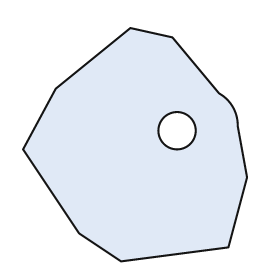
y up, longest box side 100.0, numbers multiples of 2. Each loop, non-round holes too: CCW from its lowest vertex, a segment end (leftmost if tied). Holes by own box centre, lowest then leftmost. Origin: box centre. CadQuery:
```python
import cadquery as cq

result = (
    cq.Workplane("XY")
    .moveTo(-6.0, -50.0)
    .lineTo(40.0, -44.0)
    .lineTo(48.0, -14.0)
    .lineTo(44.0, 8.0)
    .threePointArc((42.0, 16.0), (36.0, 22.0))
    .lineTo(16.0, 46.0)
    .lineTo(-2.0, 50.0)
    .lineTo(-34.0, 24.0)
    .lineTo(-48.0, -2.0)
    .lineTo(-24.0, -38.0)
    .close()
    .moveTo(18.0, 6.0)
    .circle(8.0)
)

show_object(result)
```